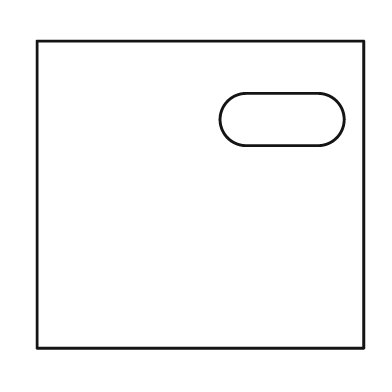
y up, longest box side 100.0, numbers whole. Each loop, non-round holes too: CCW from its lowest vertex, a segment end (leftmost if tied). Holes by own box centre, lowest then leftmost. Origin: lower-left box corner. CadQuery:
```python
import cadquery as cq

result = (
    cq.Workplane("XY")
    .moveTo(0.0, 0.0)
    .lineTo(100.0, 0.0)
    .lineTo(100.0, 94.0)
    .lineTo(0.0, 94.0)
    .close()
    .moveTo(64.0, 62.0)
    .lineTo(86.0, 62.0)
    .threePointArc((94.0, 70.0), (86.0, 78.0))
    .lineTo(64.0, 78.0)
    .threePointArc((56.0, 70.0), (64.0, 62.0))
    .close()
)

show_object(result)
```